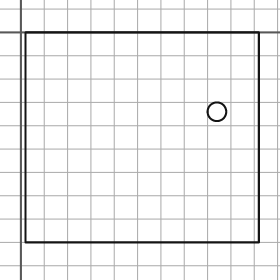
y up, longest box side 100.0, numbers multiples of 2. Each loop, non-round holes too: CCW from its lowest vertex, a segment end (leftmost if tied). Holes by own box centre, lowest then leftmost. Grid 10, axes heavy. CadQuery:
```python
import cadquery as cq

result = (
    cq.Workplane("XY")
    .moveTo(2.0, -90.0)
    .lineTo(102.0, -90.0)
    .lineTo(102.0, 0.0)
    .lineTo(2.0, 0.0)
    .close()
    .moveTo(84.0, -34.0)
    .circle(4.0)
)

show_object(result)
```